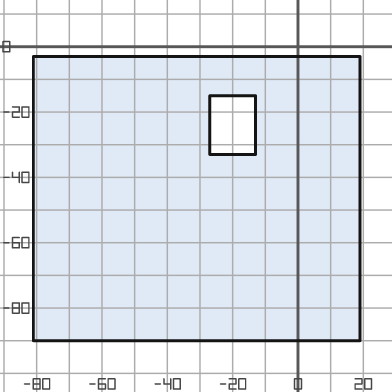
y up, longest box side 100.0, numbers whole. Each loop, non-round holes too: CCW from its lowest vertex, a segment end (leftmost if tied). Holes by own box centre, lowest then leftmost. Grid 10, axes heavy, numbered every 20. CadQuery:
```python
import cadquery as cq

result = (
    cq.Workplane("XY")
    .moveTo(-81.0, -90.0)
    .lineTo(19.0, -90.0)
    .lineTo(19.0, -3.0)
    .lineTo(-81.0, -3.0)
    .close()
    .moveTo(-27.0, -33.0)
    .lineTo(-13.0, -33.0)
    .lineTo(-13.0, -15.0)
    .lineTo(-27.0, -15.0)
    .close()
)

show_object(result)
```